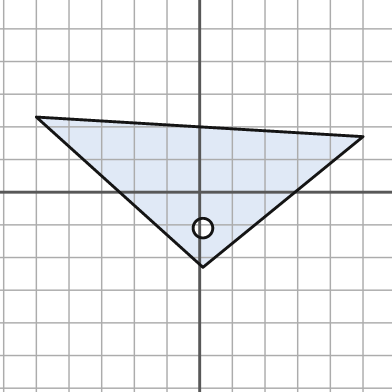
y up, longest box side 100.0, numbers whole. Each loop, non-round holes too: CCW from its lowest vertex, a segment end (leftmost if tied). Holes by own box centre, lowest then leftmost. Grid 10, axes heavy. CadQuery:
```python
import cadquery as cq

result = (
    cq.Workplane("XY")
    .moveTo(1.0, -23.0)
    .lineTo(50.0, 17.0)
    .lineTo(-50.0, 23.0)
    .close()
    .moveTo(1.0, -11.0)
    .circle(3.0)
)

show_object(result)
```